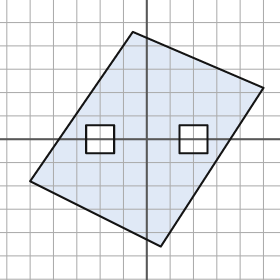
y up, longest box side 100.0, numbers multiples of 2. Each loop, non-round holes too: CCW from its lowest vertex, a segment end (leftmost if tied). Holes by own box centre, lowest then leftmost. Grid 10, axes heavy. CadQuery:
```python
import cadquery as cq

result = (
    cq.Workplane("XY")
    .moveTo(6.0, -46.0)
    .lineTo(50.0, 22.0)
    .lineTo(-6.0, 46.0)
    .lineTo(-50.0, -18.0)
    .close()
    .moveTo(-26.0, -6.0)
    .lineTo(-14.0, -6.0)
    .lineTo(-14.0, 6.0)
    .lineTo(-26.0, 6.0)
    .close()
    .moveTo(14.0, -6.0)
    .lineTo(26.0, -6.0)
    .lineTo(26.0, 6.0)
    .lineTo(14.0, 6.0)
    .close()
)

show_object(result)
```